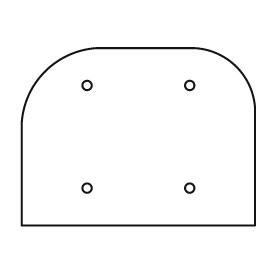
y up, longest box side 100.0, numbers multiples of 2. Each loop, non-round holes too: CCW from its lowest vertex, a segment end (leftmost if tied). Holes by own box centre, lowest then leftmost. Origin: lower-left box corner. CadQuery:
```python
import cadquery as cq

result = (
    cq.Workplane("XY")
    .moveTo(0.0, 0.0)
    .lineTo(100.0, 0.0)
    .lineTo(100.0, 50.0)
    .threePointArc((92.0, 68.0), (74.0, 76.0))
    .lineTo(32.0, 76.0)
    .threePointArc((10.0, 66.0), (0.0, 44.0))
    .close()
    .moveTo(28.0, 16.0)
    .circle(2.0)
    .moveTo(72.0, 16.0)
    .circle(2.0)
    .moveTo(28.0, 60.0)
    .circle(2.0)
    .moveTo(72.0, 60.0)
    .circle(2.0)
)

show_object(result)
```